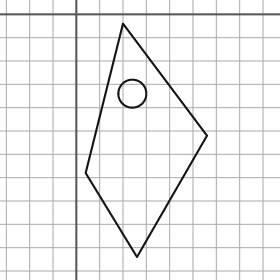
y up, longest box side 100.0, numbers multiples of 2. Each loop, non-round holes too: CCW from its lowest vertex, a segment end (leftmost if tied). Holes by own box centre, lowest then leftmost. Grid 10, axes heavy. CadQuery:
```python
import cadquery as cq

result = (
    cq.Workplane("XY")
    .moveTo(26.0, -104.0)
    .lineTo(56.0, -52.0)
    .lineTo(20.0, -4.0)
    .lineTo(4.0, -68.0)
    .close()
    .moveTo(24.0, -34.0)
    .circle(6.0)
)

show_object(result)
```